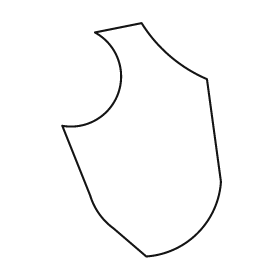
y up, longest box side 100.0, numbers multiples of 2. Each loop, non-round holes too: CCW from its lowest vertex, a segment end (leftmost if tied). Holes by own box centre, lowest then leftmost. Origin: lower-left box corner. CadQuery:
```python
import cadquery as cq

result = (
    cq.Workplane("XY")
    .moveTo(36.0, 0.0)
    .threePointArc((58.0, 10.0), (68.0, 32.0))
    .lineTo(62.0, 76.0)
    .threePointArc((46.0, 86.0), (34.0, 100.0))
    .lineTo(14.0, 96.0)
    .threePointArc((24.0, 70.0), (0.0, 56.0))
    .lineTo(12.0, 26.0)
    .threePointArc((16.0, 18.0), (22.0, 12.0))
    .close()
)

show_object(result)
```